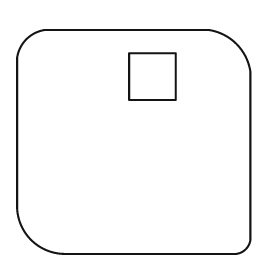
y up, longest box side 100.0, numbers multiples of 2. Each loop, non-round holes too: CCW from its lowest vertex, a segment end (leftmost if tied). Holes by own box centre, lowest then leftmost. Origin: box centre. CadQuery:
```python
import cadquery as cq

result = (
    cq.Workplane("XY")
    .moveTo(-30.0, -48.0)
    .lineTo(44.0, -48.0)
    .threePointArc((48.0, -46.0), (50.0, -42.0))
    .lineTo(50.0, 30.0)
    .threePointArc((44.0, 42.0), (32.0, 48.0))
    .lineTo(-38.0, 48.0)
    .threePointArc((-46.0, 44.0), (-50.0, 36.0))
    .lineTo(-50.0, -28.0)
    .threePointArc((-44.0, -42.0), (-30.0, -48.0))
    .close()
    .moveTo(-2.0, 18.0)
    .lineTo(18.0, 18.0)
    .lineTo(18.0, 38.0)
    .lineTo(-2.0, 38.0)
    .close()
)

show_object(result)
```